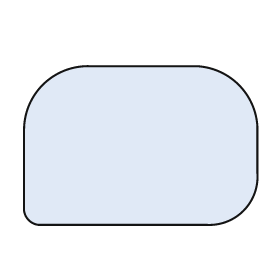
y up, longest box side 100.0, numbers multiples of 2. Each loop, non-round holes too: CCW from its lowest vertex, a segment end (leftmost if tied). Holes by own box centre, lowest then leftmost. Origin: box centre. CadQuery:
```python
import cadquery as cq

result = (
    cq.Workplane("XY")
    .moveTo(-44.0, -34.0)
    .lineTo(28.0, -34.0)
    .threePointArc((44.0, -28.0), (50.0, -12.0))
    .lineTo(50.0, 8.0)
    .threePointArc((42.0, 26.0), (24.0, 34.0))
    .lineTo(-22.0, 34.0)
    .threePointArc((-42.0, 26.0), (-50.0, 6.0))
    .lineTo(-50.0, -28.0)
    .threePointArc((-48.0, -32.0), (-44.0, -34.0))
    .close()
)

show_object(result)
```